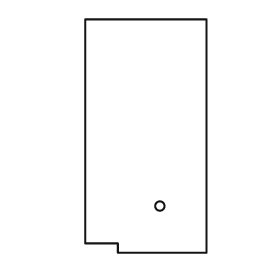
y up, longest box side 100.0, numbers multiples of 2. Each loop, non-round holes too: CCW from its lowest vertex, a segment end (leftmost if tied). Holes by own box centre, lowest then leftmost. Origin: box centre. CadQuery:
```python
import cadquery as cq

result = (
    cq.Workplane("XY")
    .moveTo(-12.0, -50.0)
    .lineTo(26.0, -50.0)
    .lineTo(26.0, 50.0)
    .lineTo(-26.0, 50.0)
    .lineTo(-26.0, -46.0)
    .lineTo(-12.0, -46.0)
    .close()
    .moveTo(6.0, -30.0)
    .circle(2.0)
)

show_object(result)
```